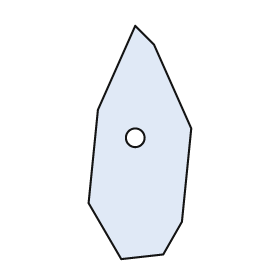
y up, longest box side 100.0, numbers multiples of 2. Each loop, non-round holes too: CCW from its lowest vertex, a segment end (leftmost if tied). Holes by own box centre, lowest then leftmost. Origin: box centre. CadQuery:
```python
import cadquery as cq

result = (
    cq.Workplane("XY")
    .moveTo(-8.0, -50.0)
    .lineTo(10.0, -48.0)
    .lineTo(18.0, -34.0)
    .lineTo(22.0, 6.0)
    .lineTo(6.0, 42.0)
    .lineTo(-2.0, 50.0)
    .lineTo(-18.0, 14.0)
    .lineTo(-22.0, -26.0)
    .close()
    .moveTo(-2.0, 2.0)
    .circle(4.0)
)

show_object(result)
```